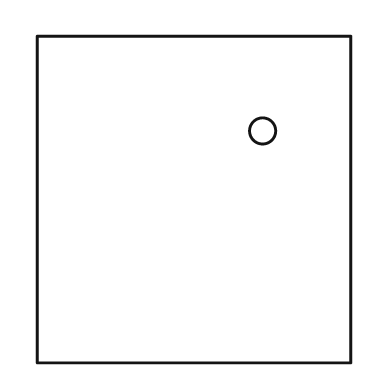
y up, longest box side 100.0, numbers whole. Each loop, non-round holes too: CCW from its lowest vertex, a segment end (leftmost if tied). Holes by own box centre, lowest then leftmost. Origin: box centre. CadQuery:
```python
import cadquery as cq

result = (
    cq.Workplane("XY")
    .moveTo(-48.0, -50.0)
    .lineTo(48.0, -50.0)
    .lineTo(48.0, 50.0)
    .lineTo(-48.0, 50.0)
    .close()
    .moveTo(21.0, 21.0)
    .circle(4.0)
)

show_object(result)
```